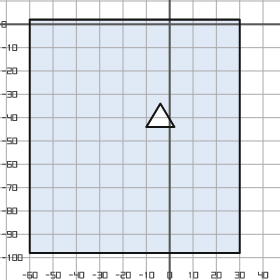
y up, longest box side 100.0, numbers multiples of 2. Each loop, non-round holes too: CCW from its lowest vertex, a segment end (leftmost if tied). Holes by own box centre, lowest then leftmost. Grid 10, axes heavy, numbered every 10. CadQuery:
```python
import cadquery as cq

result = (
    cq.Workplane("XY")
    .moveTo(-60.0, -98.0)
    .lineTo(30.0, -98.0)
    .lineTo(30.0, 2.0)
    .lineTo(-60.0, 2.0)
    .close()
    .moveTo(-10.0, -44.0)
    .lineTo(2.0, -44.0)
    .lineTo(-4.0, -34.0)
    .close()
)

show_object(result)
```